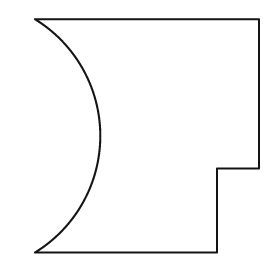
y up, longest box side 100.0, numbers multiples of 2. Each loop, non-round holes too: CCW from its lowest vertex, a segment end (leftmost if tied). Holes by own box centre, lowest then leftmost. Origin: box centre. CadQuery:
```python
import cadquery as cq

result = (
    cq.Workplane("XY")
    .moveTo(-48.0, -50.0)
    .lineTo(30.0, -50.0)
    .lineTo(30.0, -14.0)
    .lineTo(48.0, -14.0)
    .lineTo(48.0, 50.0)
    .lineTo(-48.0, 50.0)
    .threePointArc((-20.0, 0.0), (-48.0, -50.0))
    .close()
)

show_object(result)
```